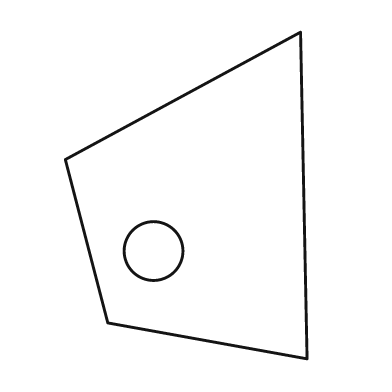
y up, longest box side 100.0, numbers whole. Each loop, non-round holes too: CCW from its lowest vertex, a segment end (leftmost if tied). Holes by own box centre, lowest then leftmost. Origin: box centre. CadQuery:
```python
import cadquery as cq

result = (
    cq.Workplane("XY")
    .moveTo(37.0, -50.0)
    .lineTo(35.0, 50.0)
    .lineTo(-37.0, 11.0)
    .lineTo(-24.0, -39.0)
    .close()
    .moveTo(-10.0, -17.0)
    .circle(9.0)
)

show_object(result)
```